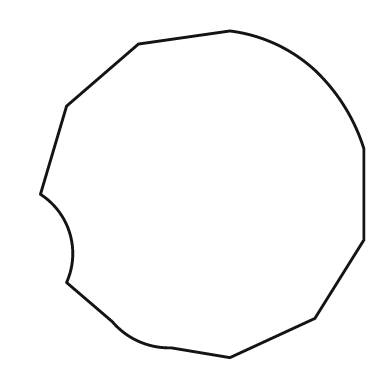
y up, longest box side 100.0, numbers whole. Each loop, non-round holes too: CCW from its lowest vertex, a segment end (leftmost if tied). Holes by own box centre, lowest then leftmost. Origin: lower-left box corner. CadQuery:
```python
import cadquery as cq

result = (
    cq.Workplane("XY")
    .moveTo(58.0, 0.0)
    .lineTo(84.0, 12.0)
    .lineTo(99.0, 36.0)
    .lineTo(99.0, 64.0)
    .threePointArc((93.0, 77.0), (84.0, 88.0))
    .threePointArc((72.0, 96.0), (58.0, 100.0))
    .lineTo(30.0, 96.0)
    .lineTo(8.0, 77.0)
    .lineTo(0.0, 50.0)
    .threePointArc((9.0, 38.0), (8.0, 23.0))
    .lineTo(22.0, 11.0)
    .threePointArc((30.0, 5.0), (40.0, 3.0))
    .close()
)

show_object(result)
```